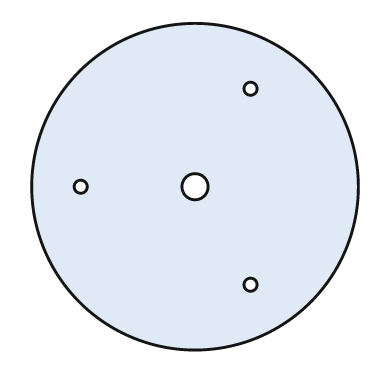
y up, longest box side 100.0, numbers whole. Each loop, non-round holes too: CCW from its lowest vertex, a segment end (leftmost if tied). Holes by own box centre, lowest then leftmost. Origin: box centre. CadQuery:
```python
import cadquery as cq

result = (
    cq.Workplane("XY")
    .moveTo(0.0, 0.0)
    .circle(50.0)
    .moveTo(17.0, -30.0)
    .circle(2.0)
    .moveTo(-35.0, 0.0)
    .circle(2.0)
    .moveTo(0.0, 0.0)
    .circle(4.0)
    .moveTo(17.0, 30.0)
    .circle(2.0)
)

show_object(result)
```